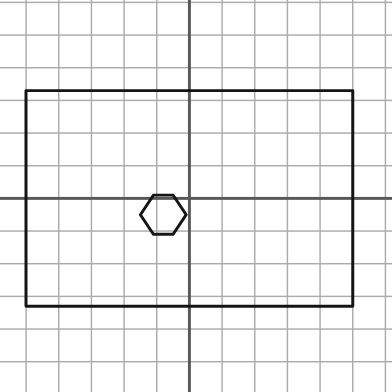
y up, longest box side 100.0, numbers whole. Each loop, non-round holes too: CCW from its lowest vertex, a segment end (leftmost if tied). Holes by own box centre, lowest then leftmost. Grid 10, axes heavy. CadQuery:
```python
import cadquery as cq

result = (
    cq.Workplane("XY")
    .moveTo(-50.0, -33.0)
    .lineTo(50.0, -33.0)
    .lineTo(50.0, 33.0)
    .lineTo(-50.0, 33.0)
    .close()
    .moveTo(-11.0, -11.0)
    .lineTo(-5.0, -11.0)
    .lineTo(-1.0, -5.0)
    .lineTo(-5.0, 1.0)
    .lineTo(-11.0, 1.0)
    .lineTo(-15.0, -5.0)
    .close()
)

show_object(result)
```